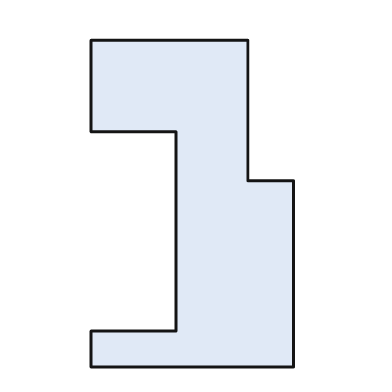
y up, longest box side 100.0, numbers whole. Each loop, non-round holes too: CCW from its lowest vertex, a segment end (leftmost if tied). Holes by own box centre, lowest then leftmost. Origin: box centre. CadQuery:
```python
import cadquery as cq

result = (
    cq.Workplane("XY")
    .moveTo(-31.0, -50.0)
    .lineTo(31.0, -50.0)
    .lineTo(31.0, 7.0)
    .lineTo(17.0, 7.0)
    .lineTo(17.0, 50.0)
    .lineTo(-31.0, 50.0)
    .lineTo(-31.0, 22.0)
    .lineTo(-5.0, 22.0)
    .lineTo(-5.0, -39.0)
    .lineTo(-31.0, -39.0)
    .close()
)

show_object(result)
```